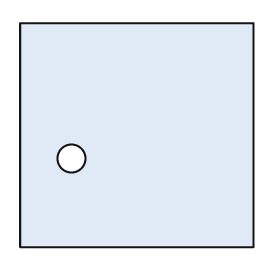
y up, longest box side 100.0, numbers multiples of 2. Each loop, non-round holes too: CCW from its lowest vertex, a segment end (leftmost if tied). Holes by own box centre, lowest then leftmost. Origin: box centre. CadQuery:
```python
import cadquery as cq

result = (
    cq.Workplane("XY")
    .moveTo(-50.0, -48.0)
    .lineTo(50.0, -48.0)
    .lineTo(50.0, 48.0)
    .lineTo(-50.0, 48.0)
    .close()
    .moveTo(-28.0, -10.0)
    .circle(6.0)
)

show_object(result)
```